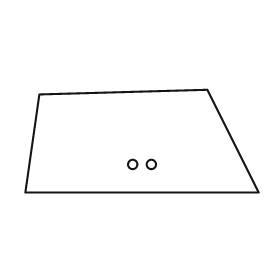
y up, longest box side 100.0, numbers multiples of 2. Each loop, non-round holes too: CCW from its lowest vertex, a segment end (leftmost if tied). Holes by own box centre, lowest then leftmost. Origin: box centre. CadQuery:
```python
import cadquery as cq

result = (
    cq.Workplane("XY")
    .moveTo(-50.0, -22.0)
    .lineTo(50.0, -22.0)
    .lineTo(28.0, 22.0)
    .lineTo(-44.0, 20.0)
    .close()
    .moveTo(-4.0, -10.0)
    .circle(2.0)
    .moveTo(4.0, -10.0)
    .circle(2.0)
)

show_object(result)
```